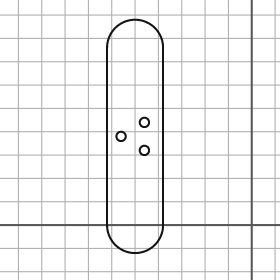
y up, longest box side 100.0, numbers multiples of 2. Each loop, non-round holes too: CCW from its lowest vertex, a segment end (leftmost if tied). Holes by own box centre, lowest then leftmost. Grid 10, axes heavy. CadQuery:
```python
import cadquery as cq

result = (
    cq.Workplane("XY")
    .moveTo(-62.0, 0.0)
    .threePointArc((-50.0, -12.0), (-38.0, 0.0))
    .lineTo(-38.0, 76.0)
    .threePointArc((-50.0, 88.0), (-62.0, 76.0))
    .close()
    .moveTo(-46.0, 32.0)
    .circle(2.0)
    .moveTo(-56.0, 38.0)
    .circle(2.0)
    .moveTo(-46.0, 44.0)
    .circle(2.0)
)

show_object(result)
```